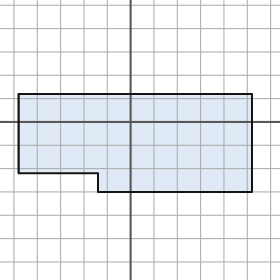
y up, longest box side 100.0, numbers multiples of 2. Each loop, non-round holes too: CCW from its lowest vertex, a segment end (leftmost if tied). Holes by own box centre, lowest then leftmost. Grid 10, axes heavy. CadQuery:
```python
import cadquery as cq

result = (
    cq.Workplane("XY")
    .moveTo(-14.0, -30.0)
    .lineTo(52.0, -30.0)
    .lineTo(52.0, 12.0)
    .lineTo(-48.0, 12.0)
    .lineTo(-48.0, -22.0)
    .lineTo(-14.0, -22.0)
    .close()
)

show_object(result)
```